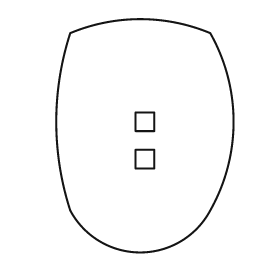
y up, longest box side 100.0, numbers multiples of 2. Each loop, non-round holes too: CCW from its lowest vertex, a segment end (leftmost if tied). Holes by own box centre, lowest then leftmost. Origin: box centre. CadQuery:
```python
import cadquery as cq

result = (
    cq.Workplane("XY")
    .moveTo(-32.0, -32.0)
    .threePointArc((-2.0, -50.0), (28.0, -32.0))
    .threePointArc((38.0, 6.0), (28.0, 44.0))
    .threePointArc((-2.0, 50.0), (-32.0, 44.0))
    .threePointArc((-38.0, 6.0), (-32.0, -32.0))
    .close()
    .moveTo(-4.0, -14.0)
    .lineTo(4.0, -14.0)
    .lineTo(4.0, -6.0)
    .lineTo(-4.0, -6.0)
    .close()
    .moveTo(-4.0, 2.0)
    .lineTo(4.0, 2.0)
    .lineTo(4.0, 10.0)
    .lineTo(-4.0, 10.0)
    .close()
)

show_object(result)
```